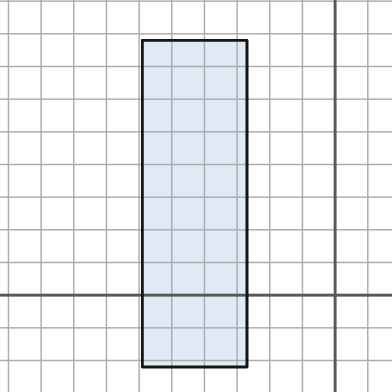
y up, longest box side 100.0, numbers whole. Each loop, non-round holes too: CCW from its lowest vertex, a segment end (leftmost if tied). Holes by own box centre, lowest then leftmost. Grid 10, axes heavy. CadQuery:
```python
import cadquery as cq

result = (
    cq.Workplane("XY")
    .moveTo(-59.0, -22.0)
    .lineTo(-27.0, -22.0)
    .lineTo(-27.0, 78.0)
    .lineTo(-59.0, 78.0)
    .close()
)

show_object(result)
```